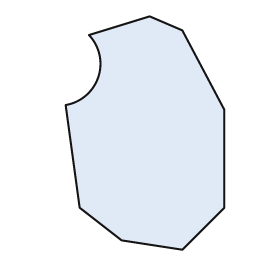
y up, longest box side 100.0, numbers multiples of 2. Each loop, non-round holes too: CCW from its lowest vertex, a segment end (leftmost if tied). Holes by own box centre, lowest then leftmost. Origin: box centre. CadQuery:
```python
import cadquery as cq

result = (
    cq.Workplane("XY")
    .moveTo(16.0, -50.0)
    .lineTo(34.0, -32.0)
    .lineTo(34.0, 10.0)
    .lineTo(16.0, 44.0)
    .lineTo(2.0, 50.0)
    .lineTo(-24.0, 42.0)
    .threePointArc((-20.0, 24.0), (-34.0, 12.0))
    .lineTo(-28.0, -32.0)
    .lineTo(-10.0, -46.0)
    .close()
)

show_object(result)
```